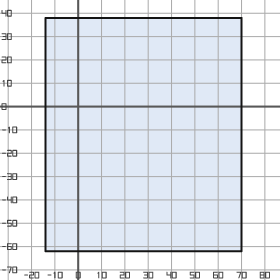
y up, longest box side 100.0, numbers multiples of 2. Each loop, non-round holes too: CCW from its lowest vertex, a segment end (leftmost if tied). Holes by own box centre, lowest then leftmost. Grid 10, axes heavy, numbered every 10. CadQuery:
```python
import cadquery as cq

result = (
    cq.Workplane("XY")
    .moveTo(-14.0, -62.0)
    .lineTo(70.0, -62.0)
    .lineTo(70.0, 38.0)
    .lineTo(-14.0, 38.0)
    .close()
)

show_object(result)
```